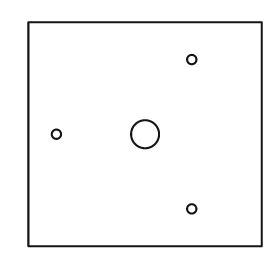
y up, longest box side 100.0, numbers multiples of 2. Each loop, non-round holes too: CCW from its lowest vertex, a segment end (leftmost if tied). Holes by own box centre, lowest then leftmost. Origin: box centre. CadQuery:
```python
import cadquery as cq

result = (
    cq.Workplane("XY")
    .moveTo(-50.0, -48.0)
    .lineTo(50.0, -48.0)
    .lineTo(50.0, 48.0)
    .lineTo(-50.0, 48.0)
    .close()
    .moveTo(20.0, -32.0)
    .circle(2.0)
    .moveTo(-38.0, 0.0)
    .circle(2.0)
    .moveTo(0.0, 0.0)
    .circle(6.0)
    .moveTo(20.0, 32.0)
    .circle(2.0)
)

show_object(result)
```